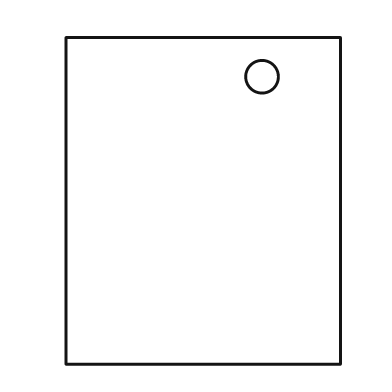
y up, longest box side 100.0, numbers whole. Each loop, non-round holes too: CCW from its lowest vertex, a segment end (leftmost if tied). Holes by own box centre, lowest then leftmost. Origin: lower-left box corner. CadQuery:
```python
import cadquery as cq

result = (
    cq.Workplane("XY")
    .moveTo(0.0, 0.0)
    .lineTo(84.0, 0.0)
    .lineTo(84.0, 100.0)
    .lineTo(0.0, 100.0)
    .close()
    .moveTo(60.0, 88.0)
    .circle(5.0)
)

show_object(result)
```